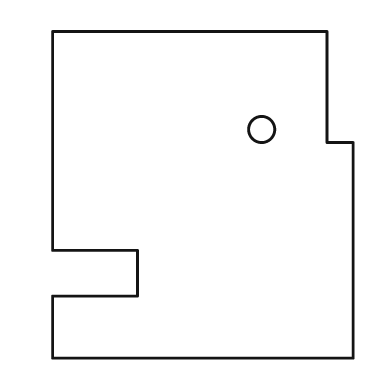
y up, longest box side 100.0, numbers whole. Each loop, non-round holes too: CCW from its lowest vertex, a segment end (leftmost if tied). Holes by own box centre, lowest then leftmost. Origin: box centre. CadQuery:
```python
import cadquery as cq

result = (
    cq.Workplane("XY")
    .moveTo(-46.0, -50.0)
    .lineTo(46.0, -50.0)
    .lineTo(46.0, 16.0)
    .lineTo(38.0, 16.0)
    .lineTo(38.0, 50.0)
    .lineTo(-46.0, 50.0)
    .lineTo(-46.0, -17.0)
    .lineTo(-20.0, -17.0)
    .lineTo(-20.0, -31.0)
    .lineTo(-46.0, -31.0)
    .close()
    .moveTo(18.0, 20.0)
    .circle(4.0)
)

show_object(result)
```